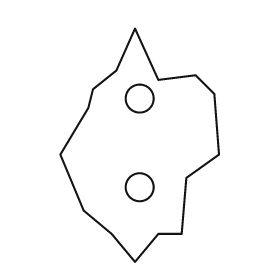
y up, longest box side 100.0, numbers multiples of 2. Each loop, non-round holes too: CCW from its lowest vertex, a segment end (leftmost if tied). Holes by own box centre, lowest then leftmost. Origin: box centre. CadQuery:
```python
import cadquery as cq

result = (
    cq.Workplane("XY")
    .moveTo(-2.0, -50.0)
    .lineTo(8.0, -38.0)
    .lineTo(18.0, -38.0)
    .lineTo(20.0, -14.0)
    .lineTo(34.0, -4.0)
    .lineTo(32.0, 22.0)
    .lineTo(24.0, 30.0)
    .lineTo(8.0, 28.0)
    .lineTo(-2.0, 50.0)
    .lineTo(-10.0, 32.0)
    .lineTo(-20.0, 24.0)
    .lineTo(-22.0, 16.0)
    .lineTo(-34.0, -4.0)
    .lineTo(-24.0, -28.0)
    .lineTo(-12.0, -38.0)
    .close()
    .moveTo(0.0, -18.0)
    .circle(6.0)
    .moveTo(0.0, 20.0)
    .circle(6.0)
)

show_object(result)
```